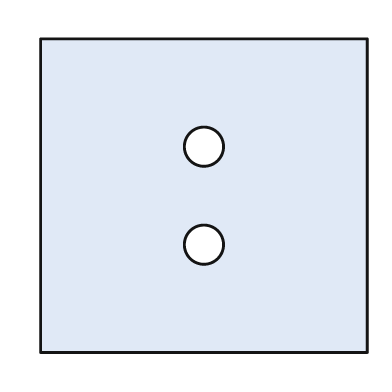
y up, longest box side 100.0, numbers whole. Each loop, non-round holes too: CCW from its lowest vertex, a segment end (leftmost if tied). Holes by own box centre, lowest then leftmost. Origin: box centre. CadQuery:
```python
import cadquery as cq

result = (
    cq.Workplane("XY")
    .moveTo(-50.0, -48.0)
    .lineTo(50.0, -48.0)
    .lineTo(50.0, 48.0)
    .lineTo(-50.0, 48.0)
    .close()
    .moveTo(0.0, -15.0)
    .circle(6.0)
    .moveTo(0.0, 15.0)
    .circle(6.0)
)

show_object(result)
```